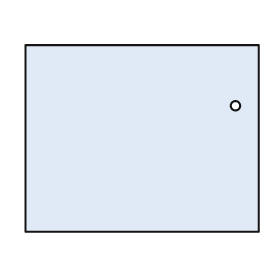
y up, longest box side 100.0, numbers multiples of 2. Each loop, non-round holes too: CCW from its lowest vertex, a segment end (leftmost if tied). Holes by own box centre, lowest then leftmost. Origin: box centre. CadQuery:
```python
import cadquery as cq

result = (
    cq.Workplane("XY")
    .moveTo(-50.0, -40.0)
    .lineTo(50.0, -40.0)
    .lineTo(50.0, 40.0)
    .lineTo(-50.0, 40.0)
    .close()
    .moveTo(40.0, 14.0)
    .circle(2.0)
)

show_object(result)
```